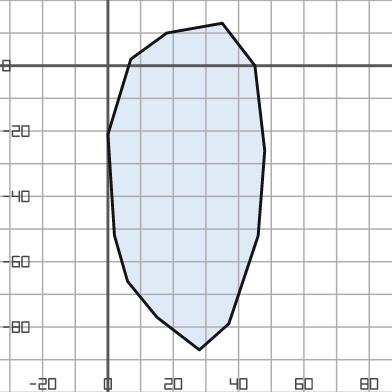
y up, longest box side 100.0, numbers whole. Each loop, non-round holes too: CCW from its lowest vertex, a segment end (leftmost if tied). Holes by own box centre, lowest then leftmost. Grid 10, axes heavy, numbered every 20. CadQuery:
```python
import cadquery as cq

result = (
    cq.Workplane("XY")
    .moveTo(28.0, -87.0)
    .lineTo(37.0, -79.0)
    .lineTo(46.0, -52.0)
    .lineTo(48.0, -26.0)
    .lineTo(45.0, 0.0)
    .lineTo(35.0, 13.0)
    .lineTo(18.0, 10.0)
    .lineTo(7.0, 2.0)
    .lineTo(0.0, -21.0)
    .lineTo(2.0, -52.0)
    .lineTo(6.0, -66.0)
    .lineTo(15.0, -77.0)
    .close()
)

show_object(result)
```